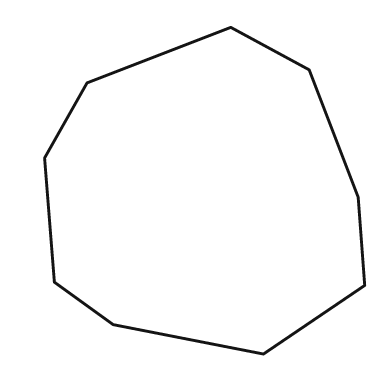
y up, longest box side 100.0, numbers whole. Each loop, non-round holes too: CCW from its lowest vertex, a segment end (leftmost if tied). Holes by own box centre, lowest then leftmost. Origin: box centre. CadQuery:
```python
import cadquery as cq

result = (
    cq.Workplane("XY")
    .moveTo(18.0, -50.0)
    .lineTo(49.0, -29.0)
    .lineTo(47.0, -2.0)
    .lineTo(32.0, 37.0)
    .lineTo(8.0, 50.0)
    .lineTo(-36.0, 33.0)
    .lineTo(-49.0, 10.0)
    .lineTo(-46.0, -28.0)
    .lineTo(-28.0, -41.0)
    .close()
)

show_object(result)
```